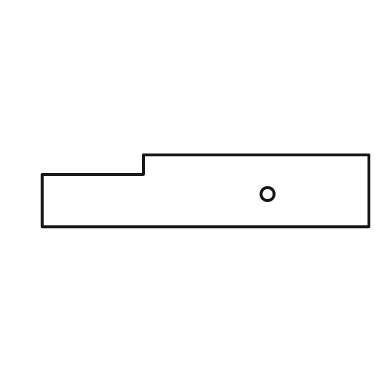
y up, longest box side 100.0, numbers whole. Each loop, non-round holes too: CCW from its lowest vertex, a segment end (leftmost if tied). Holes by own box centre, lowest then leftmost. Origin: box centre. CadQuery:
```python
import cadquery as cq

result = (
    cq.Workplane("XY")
    .moveTo(-50.0, -11.0)
    .lineTo(50.0, -11.0)
    .lineTo(50.0, 11.0)
    .lineTo(-19.0, 11.0)
    .lineTo(-19.0, 5.0)
    .lineTo(-50.0, 5.0)
    .close()
    .moveTo(19.0, -1.0)
    .circle(2.0)
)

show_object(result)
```